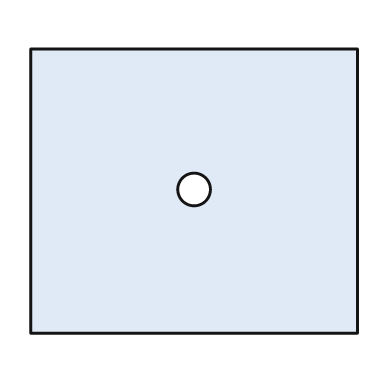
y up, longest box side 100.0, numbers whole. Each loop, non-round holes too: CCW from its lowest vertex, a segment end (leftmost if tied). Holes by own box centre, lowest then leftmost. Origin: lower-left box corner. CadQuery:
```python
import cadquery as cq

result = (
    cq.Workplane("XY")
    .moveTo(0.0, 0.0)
    .lineTo(100.0, 0.0)
    .lineTo(100.0, 87.0)
    .lineTo(0.0, 87.0)
    .close()
    .moveTo(50.0, 44.0)
    .circle(5.0)
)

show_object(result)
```